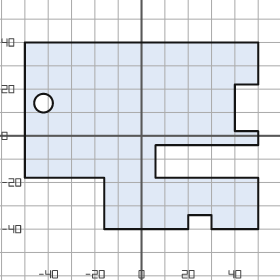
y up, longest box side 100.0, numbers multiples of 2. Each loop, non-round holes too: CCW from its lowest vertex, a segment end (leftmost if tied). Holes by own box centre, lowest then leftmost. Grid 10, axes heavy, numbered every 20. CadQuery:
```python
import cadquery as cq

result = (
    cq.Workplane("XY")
    .moveTo(-16.0, -40.0)
    .lineTo(20.0, -40.0)
    .lineTo(20.0, -34.0)
    .lineTo(30.0, -34.0)
    .lineTo(30.0, -40.0)
    .lineTo(50.0, -40.0)
    .lineTo(50.0, -18.0)
    .lineTo(6.0, -18.0)
    .lineTo(6.0, -4.0)
    .lineTo(50.0, -4.0)
    .lineTo(50.0, 2.0)
    .lineTo(40.0, 2.0)
    .lineTo(40.0, 22.0)
    .lineTo(50.0, 22.0)
    .lineTo(50.0, 40.0)
    .lineTo(-50.0, 40.0)
    .lineTo(-50.0, -18.0)
    .lineTo(-16.0, -18.0)
    .close()
    .moveTo(-42.0, 14.0)
    .circle(4.0)
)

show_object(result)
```